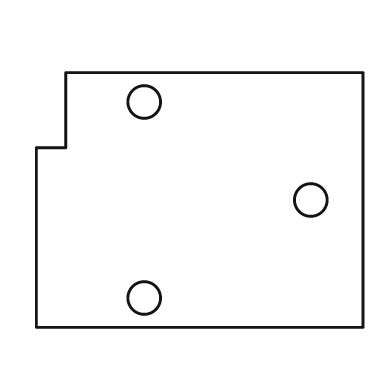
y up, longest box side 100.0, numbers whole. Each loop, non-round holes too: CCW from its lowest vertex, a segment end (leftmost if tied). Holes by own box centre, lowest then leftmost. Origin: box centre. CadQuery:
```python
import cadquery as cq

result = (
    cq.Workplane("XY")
    .moveTo(-50.0, -39.0)
    .lineTo(50.0, -39.0)
    .lineTo(50.0, 39.0)
    .lineTo(-41.0, 39.0)
    .lineTo(-41.0, 16.0)
    .lineTo(-50.0, 16.0)
    .close()
    .moveTo(-17.0, -30.0)
    .circle(5.0)
    .moveTo(34.0, 0.0)
    .circle(5.0)
    .moveTo(-17.0, 30.0)
    .circle(5.0)
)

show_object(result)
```